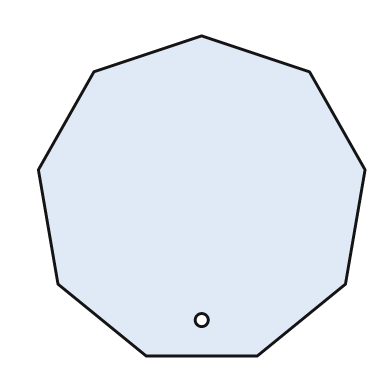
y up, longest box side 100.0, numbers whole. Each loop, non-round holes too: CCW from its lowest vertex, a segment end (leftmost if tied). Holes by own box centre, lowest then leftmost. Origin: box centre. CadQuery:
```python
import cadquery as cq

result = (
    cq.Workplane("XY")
    .moveTo(-17.0, -49.0)
    .lineTo(17.0, -49.0)
    .lineTo(44.0, -27.0)
    .lineTo(50.0, 8.0)
    .lineTo(33.0, 38.0)
    .lineTo(0.0, 49.0)
    .lineTo(-33.0, 38.0)
    .lineTo(-50.0, 8.0)
    .lineTo(-44.0, -27.0)
    .close()
    .moveTo(0.0, -38.0)
    .circle(2.0)
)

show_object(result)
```